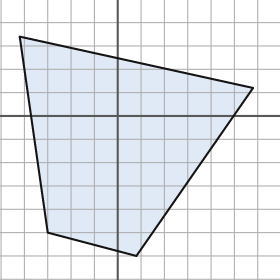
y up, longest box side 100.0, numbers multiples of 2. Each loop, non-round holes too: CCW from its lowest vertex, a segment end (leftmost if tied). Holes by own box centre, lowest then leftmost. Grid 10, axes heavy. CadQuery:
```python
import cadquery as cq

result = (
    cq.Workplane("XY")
    .moveTo(8.0, -60.0)
    .lineTo(58.0, 12.0)
    .lineTo(-42.0, 34.0)
    .lineTo(-30.0, -50.0)
    .close()
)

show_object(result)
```